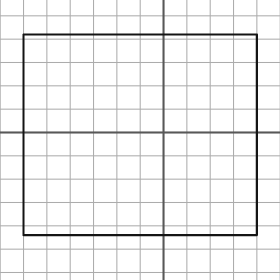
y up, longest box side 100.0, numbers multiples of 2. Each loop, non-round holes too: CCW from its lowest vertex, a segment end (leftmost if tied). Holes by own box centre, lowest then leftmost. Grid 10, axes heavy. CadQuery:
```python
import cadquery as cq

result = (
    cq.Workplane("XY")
    .moveTo(-60.0, -44.0)
    .lineTo(40.0, -44.0)
    .lineTo(40.0, 42.0)
    .lineTo(-60.0, 42.0)
    .close()
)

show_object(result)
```